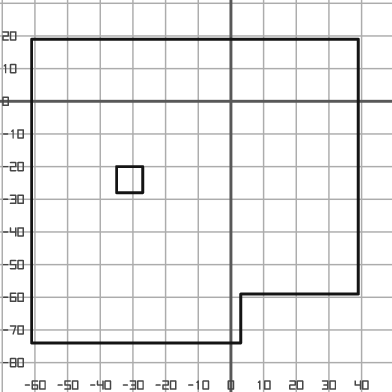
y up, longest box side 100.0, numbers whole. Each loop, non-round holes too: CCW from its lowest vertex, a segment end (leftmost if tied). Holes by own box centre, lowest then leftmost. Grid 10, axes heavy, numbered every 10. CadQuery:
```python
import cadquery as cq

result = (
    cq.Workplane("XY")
    .moveTo(-61.0, -74.0)
    .lineTo(3.0, -74.0)
    .lineTo(3.0, -59.0)
    .lineTo(39.0, -59.0)
    .lineTo(39.0, 19.0)
    .lineTo(-61.0, 19.0)
    .close()
    .moveTo(-35.0, -28.0)
    .lineTo(-27.0, -28.0)
    .lineTo(-27.0, -20.0)
    .lineTo(-35.0, -20.0)
    .close()
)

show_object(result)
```